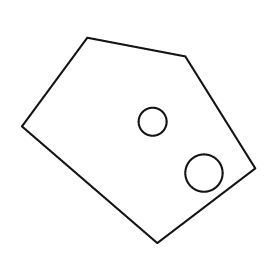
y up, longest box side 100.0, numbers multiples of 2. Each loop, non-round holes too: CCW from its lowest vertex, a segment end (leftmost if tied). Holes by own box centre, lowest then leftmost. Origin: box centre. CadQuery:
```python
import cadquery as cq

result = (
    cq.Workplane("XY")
    .moveTo(8.0, -44.0)
    .lineTo(50.0, -12.0)
    .lineTo(20.0, 36.0)
    .lineTo(-22.0, 44.0)
    .lineTo(-50.0, 6.0)
    .close()
    .moveTo(28.0, -14.0)
    .circle(8.0)
    .moveTo(6.0, 8.0)
    .circle(6.0)
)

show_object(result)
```